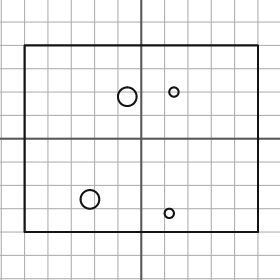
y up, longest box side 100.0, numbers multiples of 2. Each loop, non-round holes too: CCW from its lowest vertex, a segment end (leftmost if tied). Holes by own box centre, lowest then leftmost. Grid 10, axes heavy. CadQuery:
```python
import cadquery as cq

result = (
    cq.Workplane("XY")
    .moveTo(-50.0, -40.0)
    .lineTo(50.0, -40.0)
    .lineTo(50.0, 40.0)
    .lineTo(-50.0, 40.0)
    .close()
    .moveTo(12.0, -32.0)
    .circle(2.0)
    .moveTo(-22.0, -26.0)
    .circle(4.0)
    .moveTo(-6.0, 18.0)
    .circle(4.0)
    .moveTo(14.0, 20.0)
    .circle(2.0)
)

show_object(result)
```